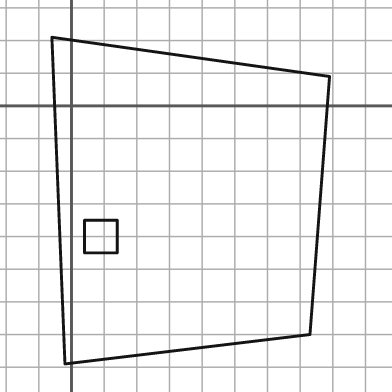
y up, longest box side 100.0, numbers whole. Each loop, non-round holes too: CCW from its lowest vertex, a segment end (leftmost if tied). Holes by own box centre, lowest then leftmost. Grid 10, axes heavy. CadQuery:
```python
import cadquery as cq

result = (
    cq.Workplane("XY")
    .moveTo(-2.0, -79.0)
    .lineTo(73.0, -70.0)
    .lineTo(79.0, 9.0)
    .lineTo(-6.0, 21.0)
    .close()
    .moveTo(4.0, -45.0)
    .lineTo(14.0, -45.0)
    .lineTo(14.0, -35.0)
    .lineTo(4.0, -35.0)
    .close()
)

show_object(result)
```